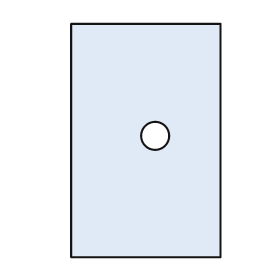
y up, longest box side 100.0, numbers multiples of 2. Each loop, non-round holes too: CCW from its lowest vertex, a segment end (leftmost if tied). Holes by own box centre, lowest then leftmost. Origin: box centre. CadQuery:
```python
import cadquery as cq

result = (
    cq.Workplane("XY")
    .moveTo(-32.0, -50.0)
    .lineTo(32.0, -50.0)
    .lineTo(32.0, 50.0)
    .lineTo(-32.0, 50.0)
    .close()
    .moveTo(4.0, 2.0)
    .circle(6.0)
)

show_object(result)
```